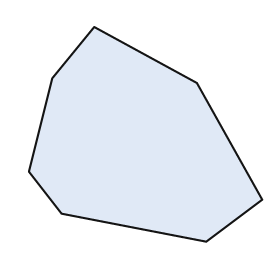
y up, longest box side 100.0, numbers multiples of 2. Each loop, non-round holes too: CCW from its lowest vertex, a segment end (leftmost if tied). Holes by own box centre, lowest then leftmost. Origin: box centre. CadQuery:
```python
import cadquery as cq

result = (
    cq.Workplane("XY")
    .moveTo(26.0, -46.0)
    .lineTo(50.0, -28.0)
    .lineTo(22.0, 22.0)
    .lineTo(-22.0, 46.0)
    .lineTo(-40.0, 24.0)
    .lineTo(-50.0, -16.0)
    .lineTo(-36.0, -34.0)
    .close()
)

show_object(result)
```